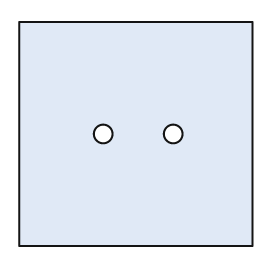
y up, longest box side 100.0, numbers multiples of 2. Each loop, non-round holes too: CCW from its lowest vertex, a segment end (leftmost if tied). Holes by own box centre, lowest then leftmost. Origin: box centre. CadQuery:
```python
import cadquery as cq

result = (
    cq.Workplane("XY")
    .moveTo(-50.0, -48.0)
    .lineTo(50.0, -48.0)
    .lineTo(50.0, 48.0)
    .lineTo(-50.0, 48.0)
    .close()
    .moveTo(-14.0, 0.0)
    .circle(4.0)
    .moveTo(16.0, 0.0)
    .circle(4.0)
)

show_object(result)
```